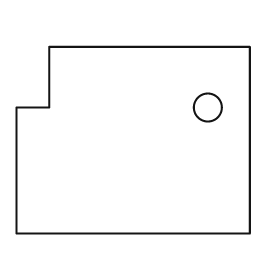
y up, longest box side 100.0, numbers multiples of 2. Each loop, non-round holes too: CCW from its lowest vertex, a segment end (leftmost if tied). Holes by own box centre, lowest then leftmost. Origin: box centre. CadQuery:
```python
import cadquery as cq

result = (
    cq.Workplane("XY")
    .moveTo(-50.0, -40.0)
    .lineTo(50.0, -40.0)
    .lineTo(50.0, 40.0)
    .lineTo(-36.0, 40.0)
    .lineTo(-36.0, 14.0)
    .lineTo(-50.0, 14.0)
    .close()
    .moveTo(32.0, 14.0)
    .circle(6.0)
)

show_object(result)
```